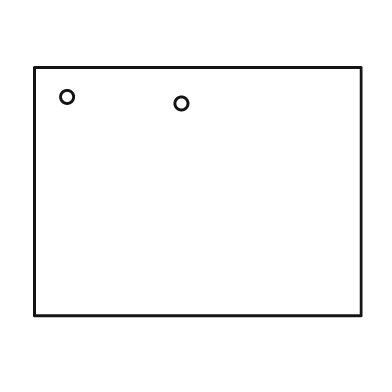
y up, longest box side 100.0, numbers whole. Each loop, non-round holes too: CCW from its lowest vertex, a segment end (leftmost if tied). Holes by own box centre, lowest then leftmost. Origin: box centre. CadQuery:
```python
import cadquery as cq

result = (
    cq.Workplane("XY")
    .moveTo(-50.0, -38.0)
    .lineTo(50.0, -38.0)
    .lineTo(50.0, 38.0)
    .lineTo(-50.0, 38.0)
    .close()
    .moveTo(-5.0, 27.0)
    .circle(2.0)
    .moveTo(-40.0, 29.0)
    .circle(2.0)
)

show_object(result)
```